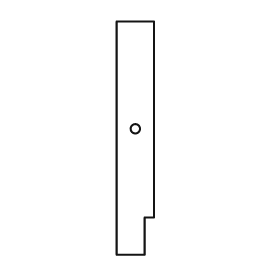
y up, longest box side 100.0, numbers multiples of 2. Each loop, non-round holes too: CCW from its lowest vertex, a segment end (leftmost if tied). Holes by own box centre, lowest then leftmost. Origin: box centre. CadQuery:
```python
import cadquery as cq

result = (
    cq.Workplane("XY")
    .moveTo(-8.0, -50.0)
    .lineTo(4.0, -50.0)
    .lineTo(4.0, -34.0)
    .lineTo(8.0, -34.0)
    .lineTo(8.0, 50.0)
    .lineTo(-8.0, 50.0)
    .close()
    .moveTo(0.0, 4.0)
    .circle(2.0)
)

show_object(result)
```